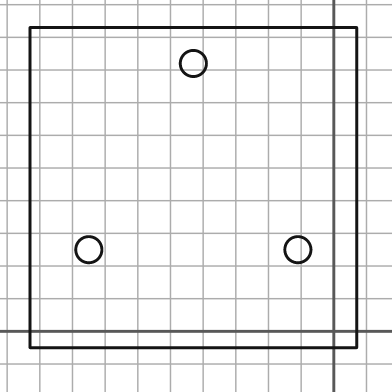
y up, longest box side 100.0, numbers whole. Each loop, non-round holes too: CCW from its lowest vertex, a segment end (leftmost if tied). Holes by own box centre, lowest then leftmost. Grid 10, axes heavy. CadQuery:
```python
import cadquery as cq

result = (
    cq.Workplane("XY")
    .moveTo(-93.0, -5.0)
    .lineTo(7.0, -5.0)
    .lineTo(7.0, 93.0)
    .lineTo(-93.0, 93.0)
    .close()
    .moveTo(-75.0, 25.0)
    .circle(4.0)
    .moveTo(-11.0, 25.0)
    .circle(4.0)
    .moveTo(-43.0, 82.0)
    .circle(4.0)
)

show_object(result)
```